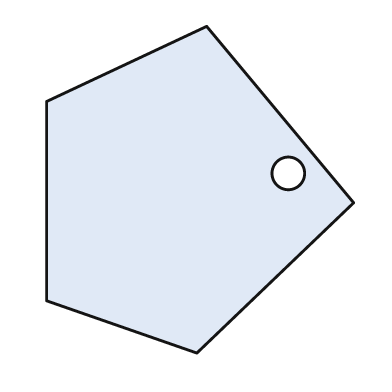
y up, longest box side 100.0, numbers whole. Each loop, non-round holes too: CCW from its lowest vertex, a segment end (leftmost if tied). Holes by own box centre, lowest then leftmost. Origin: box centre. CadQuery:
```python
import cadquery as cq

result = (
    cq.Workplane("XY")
    .moveTo(-1.0, -50.0)
    .lineTo(47.0, -4.0)
    .lineTo(2.0, 50.0)
    .lineTo(-47.0, 27.0)
    .lineTo(-47.0, -34.0)
    .close()
    .moveTo(27.0, 5.0)
    .circle(5.0)
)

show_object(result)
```